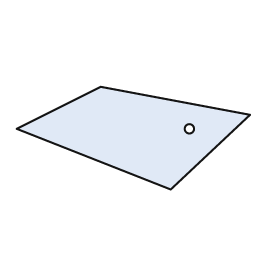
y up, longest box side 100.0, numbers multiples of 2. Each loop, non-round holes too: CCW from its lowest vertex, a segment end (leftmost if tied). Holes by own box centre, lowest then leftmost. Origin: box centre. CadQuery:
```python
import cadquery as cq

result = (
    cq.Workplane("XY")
    .moveTo(16.0, -22.0)
    .lineTo(50.0, 10.0)
    .lineTo(-14.0, 22.0)
    .lineTo(-50.0, 4.0)
    .close()
    .moveTo(24.0, 4.0)
    .circle(2.0)
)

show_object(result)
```